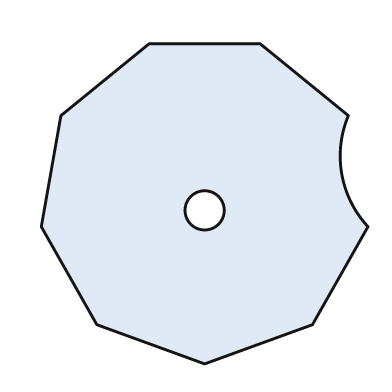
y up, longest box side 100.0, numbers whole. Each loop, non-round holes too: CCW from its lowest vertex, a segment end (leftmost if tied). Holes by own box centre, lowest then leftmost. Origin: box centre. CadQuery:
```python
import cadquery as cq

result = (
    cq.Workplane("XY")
    .moveTo(0.0, -49.0)
    .lineTo(33.0, -37.0)
    .lineTo(50.0, -7.0)
    .threePointArc((42.0, 9.0), (44.0, 27.0))
    .lineTo(17.0, 49.0)
    .lineTo(-17.0, 49.0)
    .lineTo(-44.0, 27.0)
    .lineTo(-50.0, -7.0)
    .lineTo(-33.0, -37.0)
    .close()
    .moveTo(0.0, -2.0)
    .circle(6.0)
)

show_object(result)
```